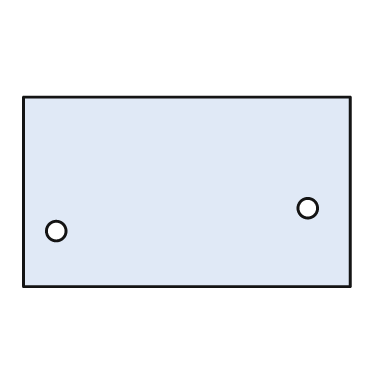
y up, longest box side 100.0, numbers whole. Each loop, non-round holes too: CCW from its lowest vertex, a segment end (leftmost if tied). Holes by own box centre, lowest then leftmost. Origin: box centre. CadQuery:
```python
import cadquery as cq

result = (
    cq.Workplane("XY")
    .moveTo(-50.0, -29.0)
    .lineTo(50.0, -29.0)
    .lineTo(50.0, 29.0)
    .lineTo(-50.0, 29.0)
    .close()
    .moveTo(-40.0, -12.0)
    .circle(3.0)
    .moveTo(37.0, -5.0)
    .circle(3.0)
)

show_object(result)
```